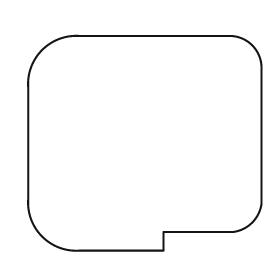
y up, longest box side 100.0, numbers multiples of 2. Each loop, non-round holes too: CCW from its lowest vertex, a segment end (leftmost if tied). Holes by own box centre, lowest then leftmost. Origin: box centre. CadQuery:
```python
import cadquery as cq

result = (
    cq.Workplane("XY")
    .moveTo(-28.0, -46.0)
    .lineTo(8.0, -46.0)
    .lineTo(8.0, -38.0)
    .lineTo(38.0, -38.0)
    .threePointArc((46.0, -34.0), (50.0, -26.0))
    .lineTo(50.0, 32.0)
    .threePointArc((46.0, 42.0), (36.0, 46.0))
    .lineTo(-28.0, 46.0)
    .threePointArc((-44.0, 40.0), (-50.0, 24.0))
    .lineTo(-50.0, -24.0)
    .threePointArc((-44.0, -40.0), (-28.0, -46.0))
    .close()
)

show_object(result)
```